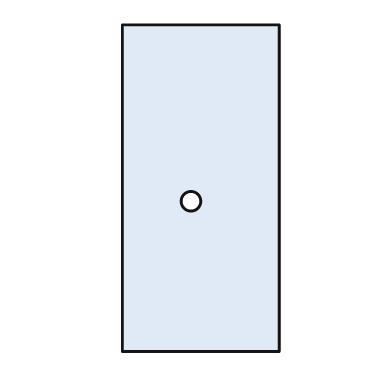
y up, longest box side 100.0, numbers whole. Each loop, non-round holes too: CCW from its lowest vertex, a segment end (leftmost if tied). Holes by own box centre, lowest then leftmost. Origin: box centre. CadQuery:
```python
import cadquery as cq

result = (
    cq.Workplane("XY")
    .moveTo(-24.0, -50.0)
    .lineTo(24.0, -50.0)
    .lineTo(24.0, 50.0)
    .lineTo(-24.0, 50.0)
    .close()
    .moveTo(-3.0, -4.0)
    .circle(3.0)
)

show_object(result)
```